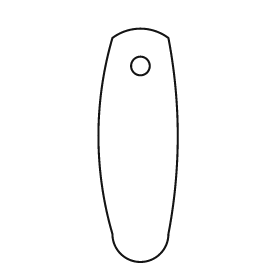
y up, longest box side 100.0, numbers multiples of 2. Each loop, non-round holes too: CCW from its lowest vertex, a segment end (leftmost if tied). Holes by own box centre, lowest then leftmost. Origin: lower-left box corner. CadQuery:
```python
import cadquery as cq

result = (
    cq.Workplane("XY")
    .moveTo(6.0, 12.0)
    .threePointArc((18.0, 0.0), (30.0, 12.0))
    .threePointArc((34.0, 54.0), (30.0, 96.0))
    .threePointArc((18.0, 100.0), (6.0, 96.0))
    .threePointArc((0.0, 54.0), (6.0, 12.0))
    .close()
    .moveTo(18.0, 84.0)
    .circle(4.0)
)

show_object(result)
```